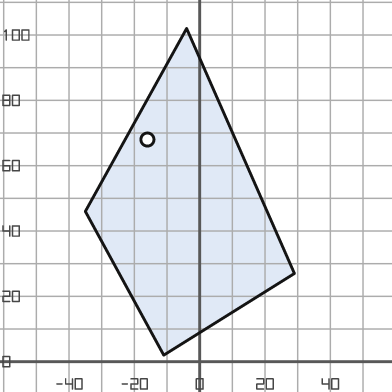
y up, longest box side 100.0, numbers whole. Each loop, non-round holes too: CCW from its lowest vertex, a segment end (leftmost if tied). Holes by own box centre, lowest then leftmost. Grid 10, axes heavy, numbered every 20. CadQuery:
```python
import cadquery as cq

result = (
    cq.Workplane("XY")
    .moveTo(-11.0, 2.0)
    .lineTo(29.0, 27.0)
    .lineTo(-4.0, 102.0)
    .lineTo(-35.0, 46.0)
    .close()
    .moveTo(-16.0, 68.0)
    .circle(2.0)
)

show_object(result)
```